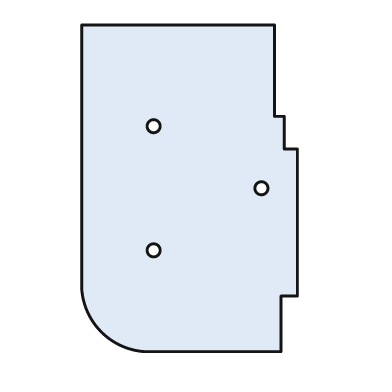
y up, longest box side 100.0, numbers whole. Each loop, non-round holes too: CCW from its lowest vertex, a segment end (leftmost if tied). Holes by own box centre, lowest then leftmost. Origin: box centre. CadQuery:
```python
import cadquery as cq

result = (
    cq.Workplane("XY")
    .moveTo(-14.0, -50.0)
    .lineTo(28.0, -50.0)
    .lineTo(28.0, -33.0)
    .lineTo(33.0, -33.0)
    .lineTo(33.0, 12.0)
    .lineTo(29.0, 12.0)
    .lineTo(29.0, 22.0)
    .lineTo(26.0, 22.0)
    .lineTo(26.0, 50.0)
    .lineTo(-33.0, 50.0)
    .lineTo(-33.0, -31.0)
    .threePointArc((-27.0, -44.0), (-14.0, -50.0))
    .close()
    .moveTo(-11.0, -19.0)
    .circle(2.0)
    .moveTo(22.0, 0.0)
    .circle(2.0)
    .moveTo(-11.0, 19.0)
    .circle(2.0)
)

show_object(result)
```